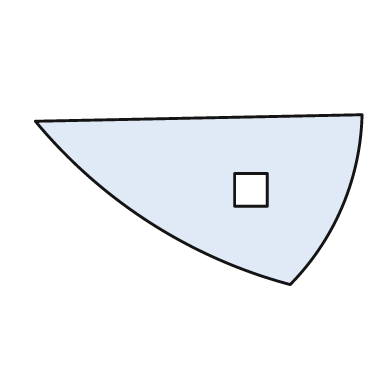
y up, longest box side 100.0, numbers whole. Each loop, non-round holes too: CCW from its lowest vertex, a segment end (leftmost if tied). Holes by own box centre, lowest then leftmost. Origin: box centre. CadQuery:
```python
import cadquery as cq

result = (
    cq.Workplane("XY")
    .moveTo(28.0, -26.0)
    .threePointArc((44.0, -2.0), (50.0, 26.0))
    .lineTo(-50.0, 24.0)
    .threePointArc((-15.0, -7.0), (28.0, -26.0))
    .close()
    .moveTo(11.0, -2.0)
    .lineTo(21.0, -2.0)
    .lineTo(21.0, 8.0)
    .lineTo(11.0, 8.0)
    .close()
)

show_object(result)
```